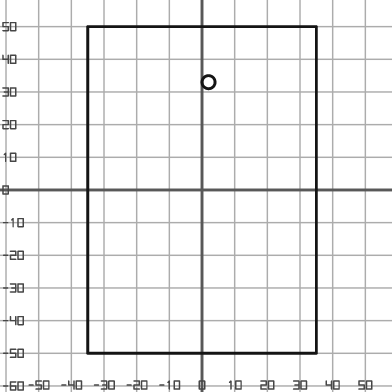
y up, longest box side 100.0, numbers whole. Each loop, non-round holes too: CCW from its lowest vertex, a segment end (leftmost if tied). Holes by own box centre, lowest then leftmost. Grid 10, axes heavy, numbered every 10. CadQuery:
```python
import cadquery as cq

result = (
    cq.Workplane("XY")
    .moveTo(-35.0, -50.0)
    .lineTo(35.0, -50.0)
    .lineTo(35.0, 50.0)
    .lineTo(-35.0, 50.0)
    .close()
    .moveTo(2.0, 33.0)
    .circle(2.0)
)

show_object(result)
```